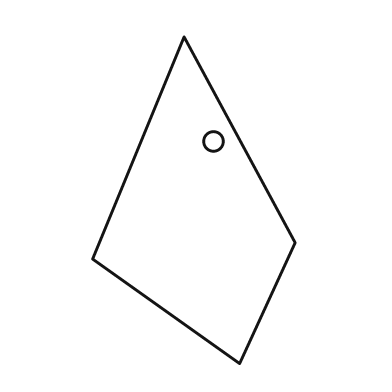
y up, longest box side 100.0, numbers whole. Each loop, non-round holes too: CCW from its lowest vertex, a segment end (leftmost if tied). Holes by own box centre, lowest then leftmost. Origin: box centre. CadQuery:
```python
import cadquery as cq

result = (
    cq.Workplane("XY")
    .moveTo(14.0, -50.0)
    .lineTo(31.0, -13.0)
    .lineTo(-3.0, 50.0)
    .lineTo(-31.0, -18.0)
    .close()
    .moveTo(6.0, 18.0)
    .circle(3.0)
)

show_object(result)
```